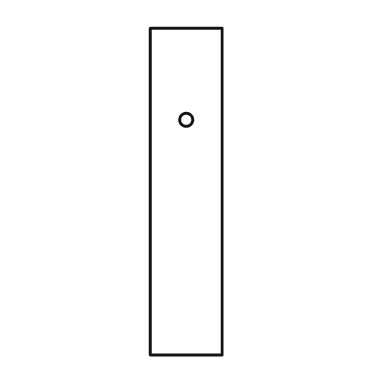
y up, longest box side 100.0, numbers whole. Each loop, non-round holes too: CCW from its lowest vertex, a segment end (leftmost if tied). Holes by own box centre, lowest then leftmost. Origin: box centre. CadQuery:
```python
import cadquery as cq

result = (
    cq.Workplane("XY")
    .moveTo(-11.0, -50.0)
    .lineTo(11.0, -50.0)
    .lineTo(11.0, 50.0)
    .lineTo(-11.0, 50.0)
    .close()
    .moveTo(0.0, 22.0)
    .circle(2.0)
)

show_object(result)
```